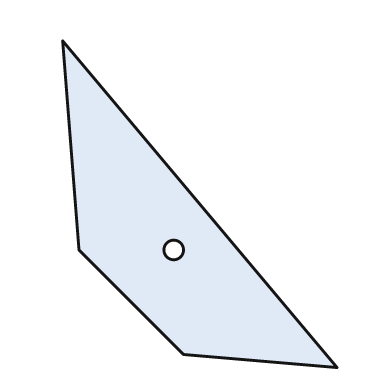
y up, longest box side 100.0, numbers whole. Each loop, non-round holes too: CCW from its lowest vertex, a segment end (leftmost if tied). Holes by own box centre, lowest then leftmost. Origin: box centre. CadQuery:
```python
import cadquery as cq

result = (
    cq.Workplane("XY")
    .moveTo(42.0, -50.0)
    .lineTo(-42.0, 50.0)
    .lineTo(-37.0, -14.0)
    .lineTo(-5.0, -46.0)
    .close()
    .moveTo(-8.0, -14.0)
    .circle(3.0)
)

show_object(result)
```